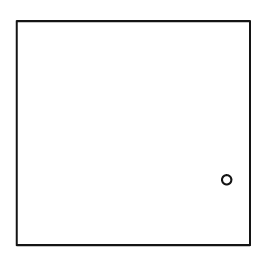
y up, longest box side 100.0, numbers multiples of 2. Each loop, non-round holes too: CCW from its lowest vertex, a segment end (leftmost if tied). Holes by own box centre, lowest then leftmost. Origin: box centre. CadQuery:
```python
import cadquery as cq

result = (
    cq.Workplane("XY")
    .moveTo(-50.0, -48.0)
    .lineTo(50.0, -48.0)
    .lineTo(50.0, 48.0)
    .lineTo(-50.0, 48.0)
    .close()
    .moveTo(40.0, -20.0)
    .circle(2.0)
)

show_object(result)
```